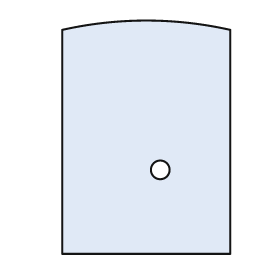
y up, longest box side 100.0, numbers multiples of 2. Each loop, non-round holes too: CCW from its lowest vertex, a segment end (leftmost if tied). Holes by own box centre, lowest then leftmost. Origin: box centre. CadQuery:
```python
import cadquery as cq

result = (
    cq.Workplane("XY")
    .moveTo(-36.0, -50.0)
    .lineTo(36.0, -50.0)
    .lineTo(36.0, 46.0)
    .threePointArc((0.0, 50.0), (-36.0, 46.0))
    .close()
    .moveTo(6.0, -14.0)
    .circle(4.0)
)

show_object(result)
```